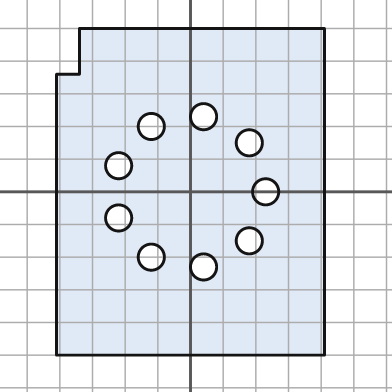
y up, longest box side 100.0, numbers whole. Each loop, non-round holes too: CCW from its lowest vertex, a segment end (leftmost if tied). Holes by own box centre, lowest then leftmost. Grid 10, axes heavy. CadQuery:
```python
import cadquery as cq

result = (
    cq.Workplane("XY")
    .moveTo(-41.0, -50.0)
    .lineTo(41.0, -50.0)
    .lineTo(41.0, 50.0)
    .lineTo(-34.0, 50.0)
    .lineTo(-34.0, 36.0)
    .lineTo(-41.0, 36.0)
    .close()
    .moveTo(4.0, -23.0)
    .circle(4.0)
    .moveTo(-12.0, -20.0)
    .circle(4.0)
    .moveTo(18.0, -15.0)
    .circle(4.0)
    .moveTo(-22.0, -8.0)
    .circle(4.0)
    .moveTo(23.0, 0.0)
    .circle(4.0)
    .moveTo(-22.0, 8.0)
    .circle(4.0)
    .moveTo(18.0, 15.0)
    .circle(4.0)
    .moveTo(-12.0, 20.0)
    .circle(4.0)
    .moveTo(4.0, 23.0)
    .circle(4.0)
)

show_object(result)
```